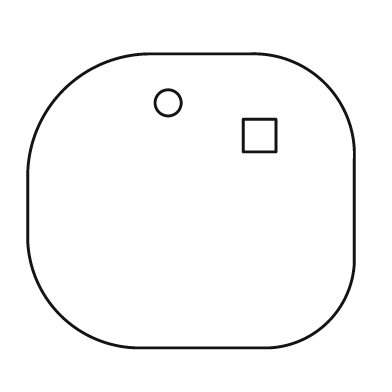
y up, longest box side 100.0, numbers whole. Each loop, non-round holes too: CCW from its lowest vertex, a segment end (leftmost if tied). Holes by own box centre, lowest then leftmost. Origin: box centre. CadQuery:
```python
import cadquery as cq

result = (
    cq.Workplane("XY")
    .moveTo(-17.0, -45.0)
    .lineTo(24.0, -45.0)
    .threePointArc((42.0, -37.0), (50.0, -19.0))
    .lineTo(50.0, 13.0)
    .threePointArc((41.0, 36.0), (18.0, 45.0))
    .lineTo(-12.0, 45.0)
    .threePointArc((-39.0, 34.0), (-50.0, 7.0))
    .lineTo(-50.0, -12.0)
    .threePointArc((-40.0, -35.0), (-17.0, -45.0))
    .close()
    .moveTo(16.0, 15.0)
    .lineTo(26.0, 15.0)
    .lineTo(26.0, 25.0)
    .lineTo(16.0, 25.0)
    .close()
    .moveTo(-7.0, 30.0)
    .circle(4.0)
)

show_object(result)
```